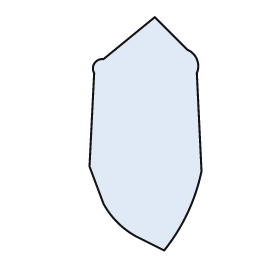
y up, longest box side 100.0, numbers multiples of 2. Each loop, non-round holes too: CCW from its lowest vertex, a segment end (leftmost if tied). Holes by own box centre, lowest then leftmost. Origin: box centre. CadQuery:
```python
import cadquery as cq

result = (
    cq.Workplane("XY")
    .moveTo(8.0, -50.0)
    .threePointArc((18.0, -34.0), (24.0, -16.0))
    .lineTo(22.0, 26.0)
    .threePointArc((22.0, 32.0), (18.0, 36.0))
    .lineTo(4.0, 50.0)
    .lineTo(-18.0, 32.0)
    .threePointArc((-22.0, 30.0), (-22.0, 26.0))
    .lineTo(-24.0, -14.0)
    .lineTo(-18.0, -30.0)
    .threePointArc((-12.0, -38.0), (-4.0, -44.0))
    .close()
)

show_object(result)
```